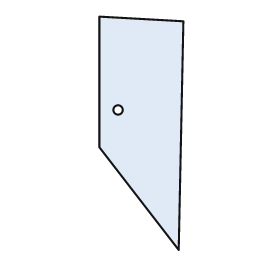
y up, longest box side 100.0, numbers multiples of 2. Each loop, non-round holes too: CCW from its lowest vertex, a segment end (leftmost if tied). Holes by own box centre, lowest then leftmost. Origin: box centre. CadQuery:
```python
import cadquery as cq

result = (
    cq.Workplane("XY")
    .moveTo(16.0, -50.0)
    .lineTo(18.0, 48.0)
    .lineTo(-18.0, 50.0)
    .lineTo(-18.0, -6.0)
    .close()
    .moveTo(-10.0, 10.0)
    .circle(2.0)
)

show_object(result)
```